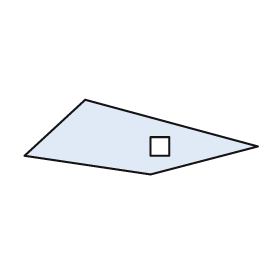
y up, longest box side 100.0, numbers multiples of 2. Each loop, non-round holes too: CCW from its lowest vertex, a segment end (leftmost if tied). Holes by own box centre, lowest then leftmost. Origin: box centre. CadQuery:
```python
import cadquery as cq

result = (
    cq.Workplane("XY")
    .moveTo(4.0, -16.0)
    .lineTo(50.0, -4.0)
    .lineTo(-24.0, 16.0)
    .lineTo(-50.0, -8.0)
    .close()
    .moveTo(4.0, -8.0)
    .lineTo(12.0, -8.0)
    .lineTo(12.0, 0.0)
    .lineTo(4.0, 0.0)
    .close()
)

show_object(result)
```